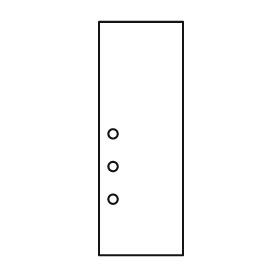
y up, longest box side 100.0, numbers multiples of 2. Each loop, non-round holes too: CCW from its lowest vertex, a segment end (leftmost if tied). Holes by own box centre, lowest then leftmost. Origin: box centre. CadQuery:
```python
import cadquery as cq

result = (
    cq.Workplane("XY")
    .moveTo(-18.0, -50.0)
    .lineTo(18.0, -50.0)
    .lineTo(18.0, 50.0)
    .lineTo(-18.0, 50.0)
    .close()
    .moveTo(-12.0, -26.0)
    .circle(2.0)
    .moveTo(-12.0, -12.0)
    .circle(2.0)
    .moveTo(-12.0, 2.0)
    .circle(2.0)
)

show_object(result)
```